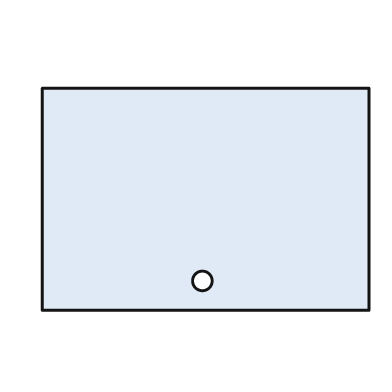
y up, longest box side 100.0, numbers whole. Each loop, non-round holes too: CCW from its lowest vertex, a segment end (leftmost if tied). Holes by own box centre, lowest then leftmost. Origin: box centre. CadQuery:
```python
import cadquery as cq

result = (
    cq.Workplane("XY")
    .moveTo(-50.0, -34.0)
    .lineTo(50.0, -34.0)
    .lineTo(50.0, 34.0)
    .lineTo(-50.0, 34.0)
    .close()
    .moveTo(-1.0, -25.0)
    .circle(3.0)
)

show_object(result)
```